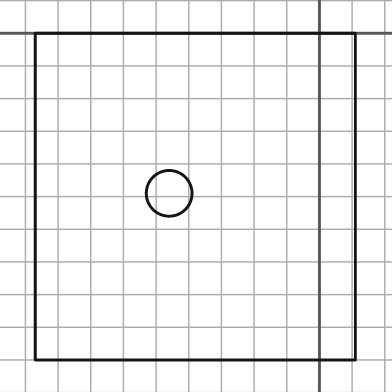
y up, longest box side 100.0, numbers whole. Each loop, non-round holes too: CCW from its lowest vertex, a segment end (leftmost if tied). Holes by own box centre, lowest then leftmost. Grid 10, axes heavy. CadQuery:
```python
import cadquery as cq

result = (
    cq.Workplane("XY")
    .moveTo(-87.0, -100.0)
    .lineTo(11.0, -100.0)
    .lineTo(11.0, 0.0)
    .lineTo(-87.0, 0.0)
    .close()
    .moveTo(-46.0, -49.0)
    .circle(7.0)
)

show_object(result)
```